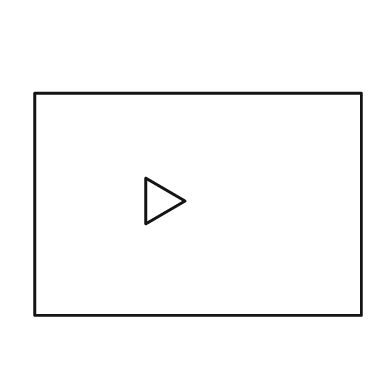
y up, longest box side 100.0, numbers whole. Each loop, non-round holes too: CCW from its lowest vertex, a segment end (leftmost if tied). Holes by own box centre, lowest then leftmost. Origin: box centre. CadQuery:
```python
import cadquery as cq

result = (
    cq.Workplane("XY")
    .moveTo(-50.0, -34.0)
    .lineTo(50.0, -34.0)
    .lineTo(50.0, 34.0)
    .lineTo(-50.0, 34.0)
    .close()
    .moveTo(-16.0, -6.0)
    .lineTo(-4.0, 1.0)
    .lineTo(-16.0, 8.0)
    .close()
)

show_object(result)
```